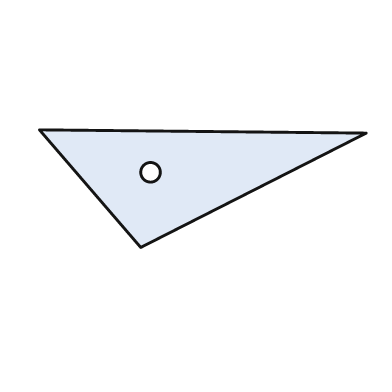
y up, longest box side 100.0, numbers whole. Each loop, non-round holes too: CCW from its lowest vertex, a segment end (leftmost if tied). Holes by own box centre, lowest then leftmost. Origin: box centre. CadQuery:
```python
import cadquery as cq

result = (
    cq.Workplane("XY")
    .moveTo(-19.0, -18.0)
    .lineTo(50.0, 17.0)
    .lineTo(-50.0, 18.0)
    .close()
    .moveTo(-16.0, 5.0)
    .circle(3.0)
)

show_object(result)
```